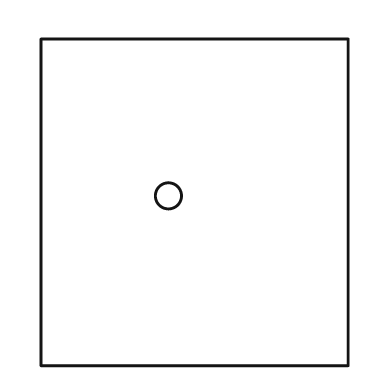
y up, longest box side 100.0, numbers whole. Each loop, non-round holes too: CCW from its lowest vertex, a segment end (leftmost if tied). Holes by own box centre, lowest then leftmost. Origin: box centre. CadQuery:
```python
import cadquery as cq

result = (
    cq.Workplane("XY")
    .moveTo(-47.0, -50.0)
    .lineTo(47.0, -50.0)
    .lineTo(47.0, 50.0)
    .lineTo(-47.0, 50.0)
    .close()
    .moveTo(-8.0, 2.0)
    .circle(4.0)
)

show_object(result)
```